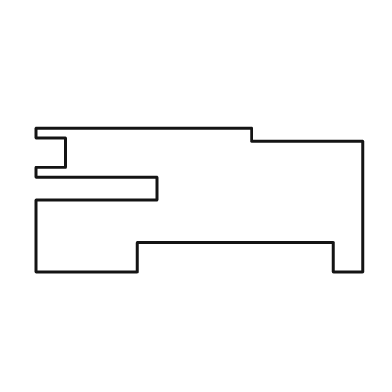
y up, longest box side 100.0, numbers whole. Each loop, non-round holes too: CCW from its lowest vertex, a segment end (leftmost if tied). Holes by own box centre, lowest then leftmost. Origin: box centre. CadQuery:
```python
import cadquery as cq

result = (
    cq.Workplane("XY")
    .moveTo(-50.0, -22.0)
    .lineTo(-19.0, -22.0)
    .lineTo(-19.0, -13.0)
    .lineTo(41.0, -13.0)
    .lineTo(41.0, -22.0)
    .lineTo(50.0, -22.0)
    .lineTo(50.0, 18.0)
    .lineTo(16.0, 18.0)
    .lineTo(16.0, 22.0)
    .lineTo(-50.0, 22.0)
    .lineTo(-50.0, 19.0)
    .lineTo(-41.0, 19.0)
    .lineTo(-41.0, 10.0)
    .lineTo(-50.0, 10.0)
    .lineTo(-50.0, 7.0)
    .lineTo(-13.0, 7.0)
    .lineTo(-13.0, 0.0)
    .lineTo(-50.0, 0.0)
    .close()
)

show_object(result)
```